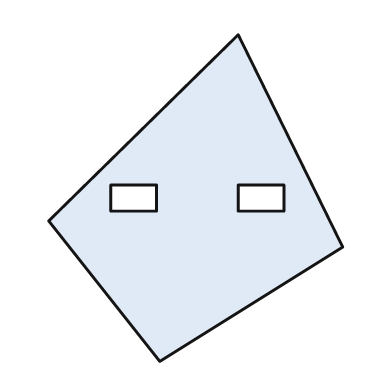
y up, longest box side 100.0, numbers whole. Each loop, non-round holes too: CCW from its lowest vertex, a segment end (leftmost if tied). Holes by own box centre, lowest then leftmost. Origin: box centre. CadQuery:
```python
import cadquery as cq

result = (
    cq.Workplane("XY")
    .moveTo(-11.0, -50.0)
    .lineTo(45.0, -15.0)
    .lineTo(13.0, 50.0)
    .lineTo(-45.0, -7.0)
    .close()
    .moveTo(-26.0, -4.0)
    .lineTo(-12.0, -4.0)
    .lineTo(-12.0, 4.0)
    .lineTo(-26.0, 4.0)
    .close()
    .moveTo(13.0, -4.0)
    .lineTo(27.0, -4.0)
    .lineTo(27.0, 4.0)
    .lineTo(13.0, 4.0)
    .close()
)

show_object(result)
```